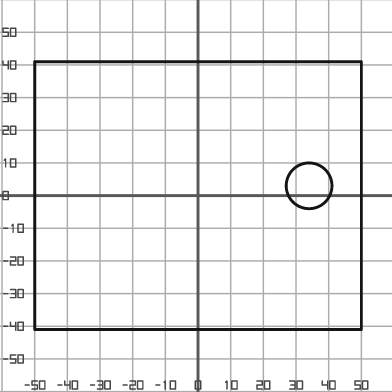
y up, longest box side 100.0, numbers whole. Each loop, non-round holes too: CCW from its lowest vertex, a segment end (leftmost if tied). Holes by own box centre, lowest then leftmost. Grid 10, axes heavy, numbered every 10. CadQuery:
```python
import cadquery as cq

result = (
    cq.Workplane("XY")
    .moveTo(-50.0, -41.0)
    .lineTo(50.0, -41.0)
    .lineTo(50.0, 41.0)
    .lineTo(-50.0, 41.0)
    .close()
    .moveTo(34.0, 3.0)
    .circle(7.0)
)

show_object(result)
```